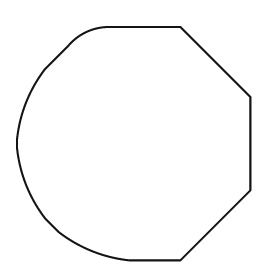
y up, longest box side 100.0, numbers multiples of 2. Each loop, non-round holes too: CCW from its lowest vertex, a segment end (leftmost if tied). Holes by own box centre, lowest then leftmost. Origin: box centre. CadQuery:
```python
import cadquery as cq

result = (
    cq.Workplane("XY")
    .moveTo(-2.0, -50.0)
    .lineTo(20.0, -50.0)
    .lineTo(50.0, -20.0)
    .lineTo(50.0, 20.0)
    .lineTo(20.0, 50.0)
    .lineTo(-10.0, 50.0)
    .threePointArc((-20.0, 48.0), (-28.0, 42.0))
    .lineTo(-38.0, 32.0)
    .threePointArc((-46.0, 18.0), (-50.0, 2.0))
    .lineTo(-50.0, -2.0)
    .threePointArc((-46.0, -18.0), (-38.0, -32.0))
    .lineTo(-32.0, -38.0)
    .threePointArc((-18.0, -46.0), (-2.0, -50.0))
    .close()
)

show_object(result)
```